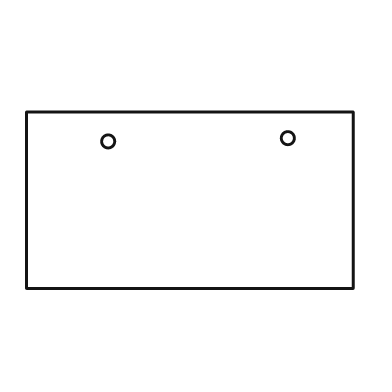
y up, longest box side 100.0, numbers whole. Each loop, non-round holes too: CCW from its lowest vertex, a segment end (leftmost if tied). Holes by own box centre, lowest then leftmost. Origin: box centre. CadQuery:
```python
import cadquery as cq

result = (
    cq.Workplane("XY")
    .moveTo(-50.0, -27.0)
    .lineTo(50.0, -27.0)
    .lineTo(50.0, 27.0)
    .lineTo(-50.0, 27.0)
    .close()
    .moveTo(-25.0, 18.0)
    .circle(2.0)
    .moveTo(30.0, 19.0)
    .circle(2.0)
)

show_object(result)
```